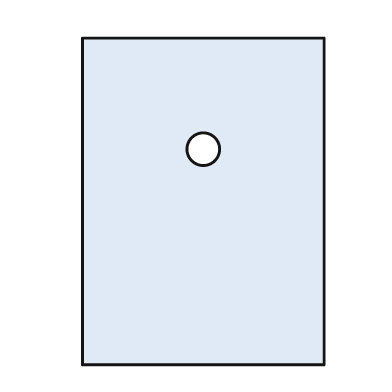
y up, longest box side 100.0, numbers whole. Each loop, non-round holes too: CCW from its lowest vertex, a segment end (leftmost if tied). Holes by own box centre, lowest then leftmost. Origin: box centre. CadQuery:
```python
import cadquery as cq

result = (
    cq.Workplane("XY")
    .moveTo(-37.0, -50.0)
    .lineTo(37.0, -50.0)
    .lineTo(37.0, 50.0)
    .lineTo(-37.0, 50.0)
    .close()
    .moveTo(0.0, 16.0)
    .circle(5.0)
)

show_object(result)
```